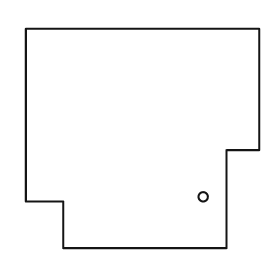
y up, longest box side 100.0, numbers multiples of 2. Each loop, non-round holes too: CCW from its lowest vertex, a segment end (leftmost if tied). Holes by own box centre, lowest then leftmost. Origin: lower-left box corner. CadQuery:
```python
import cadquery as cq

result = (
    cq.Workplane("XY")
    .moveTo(16.0, 0.0)
    .lineTo(86.0, 0.0)
    .lineTo(86.0, 42.0)
    .lineTo(100.0, 42.0)
    .lineTo(100.0, 94.0)
    .lineTo(0.0, 94.0)
    .lineTo(0.0, 20.0)
    .lineTo(16.0, 20.0)
    .close()
    .moveTo(76.0, 22.0)
    .circle(2.0)
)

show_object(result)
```